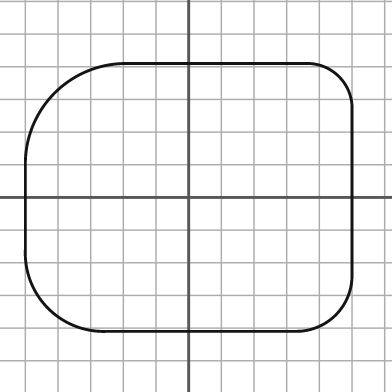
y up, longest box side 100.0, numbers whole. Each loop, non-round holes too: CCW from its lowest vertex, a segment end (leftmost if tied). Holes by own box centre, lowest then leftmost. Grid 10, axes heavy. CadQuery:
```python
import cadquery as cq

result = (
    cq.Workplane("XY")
    .moveTo(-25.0, -41.0)
    .lineTo(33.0, -41.0)
    .threePointArc((45.0, -36.0), (50.0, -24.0))
    .lineTo(50.0, 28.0)
    .threePointArc((46.0, 37.0), (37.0, 41.0))
    .lineTo(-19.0, 41.0)
    .threePointArc((-41.0, 32.0), (-50.0, 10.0))
    .lineTo(-50.0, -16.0)
    .threePointArc((-43.0, -34.0), (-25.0, -41.0))
    .close()
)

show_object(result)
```